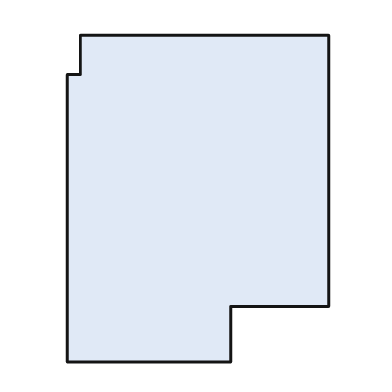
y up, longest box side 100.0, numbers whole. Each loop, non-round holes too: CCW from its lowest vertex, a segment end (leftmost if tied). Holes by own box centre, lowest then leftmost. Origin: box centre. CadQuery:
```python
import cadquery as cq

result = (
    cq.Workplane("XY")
    .moveTo(-40.0, -50.0)
    .lineTo(10.0, -50.0)
    .lineTo(10.0, -33.0)
    .lineTo(40.0, -33.0)
    .lineTo(40.0, 50.0)
    .lineTo(-36.0, 50.0)
    .lineTo(-36.0, 38.0)
    .lineTo(-40.0, 38.0)
    .close()
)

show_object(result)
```